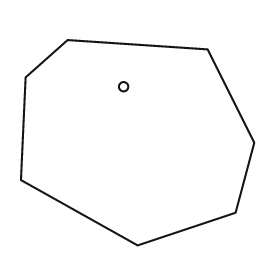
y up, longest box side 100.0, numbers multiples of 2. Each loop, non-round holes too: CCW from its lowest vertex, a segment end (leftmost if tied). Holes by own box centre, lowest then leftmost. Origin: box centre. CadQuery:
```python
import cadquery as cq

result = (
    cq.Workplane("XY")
    .moveTo(0.0, -44.0)
    .lineTo(42.0, -30.0)
    .lineTo(50.0, 0.0)
    .lineTo(30.0, 40.0)
    .lineTo(-30.0, 44.0)
    .lineTo(-48.0, 28.0)
    .lineTo(-50.0, -16.0)
    .close()
    .moveTo(-6.0, 24.0)
    .circle(2.0)
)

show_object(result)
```